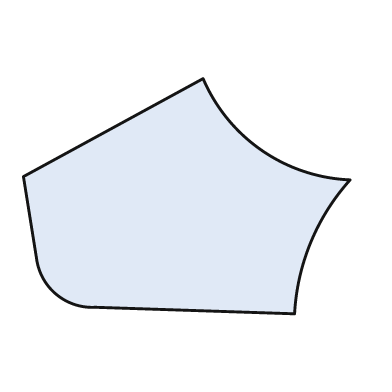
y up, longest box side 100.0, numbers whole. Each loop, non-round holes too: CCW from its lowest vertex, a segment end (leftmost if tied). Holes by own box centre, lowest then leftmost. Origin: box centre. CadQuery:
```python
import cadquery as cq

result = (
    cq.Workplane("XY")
    .moveTo(33.0, -36.0)
    .threePointArc((38.0, -14.0), (50.0, 5.0))
    .threePointArc((23.0, 14.0), (5.0, 36.0))
    .lineTo(-50.0, 6.0)
    .lineTo(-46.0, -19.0)
    .threePointArc((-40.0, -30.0), (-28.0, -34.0))
    .close()
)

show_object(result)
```